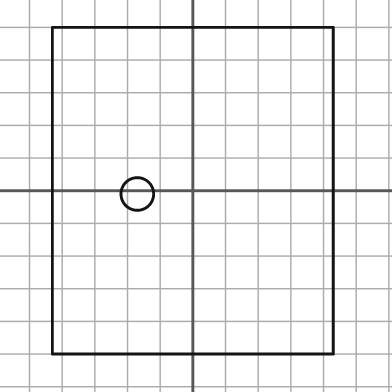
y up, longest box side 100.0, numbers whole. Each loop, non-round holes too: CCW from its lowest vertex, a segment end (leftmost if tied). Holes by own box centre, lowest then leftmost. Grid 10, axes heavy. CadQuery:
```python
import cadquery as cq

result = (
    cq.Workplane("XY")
    .moveTo(-43.0, -50.0)
    .lineTo(43.0, -50.0)
    .lineTo(43.0, 50.0)
    .lineTo(-43.0, 50.0)
    .close()
    .moveTo(-17.0, -1.0)
    .circle(5.0)
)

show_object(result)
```